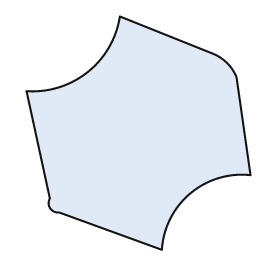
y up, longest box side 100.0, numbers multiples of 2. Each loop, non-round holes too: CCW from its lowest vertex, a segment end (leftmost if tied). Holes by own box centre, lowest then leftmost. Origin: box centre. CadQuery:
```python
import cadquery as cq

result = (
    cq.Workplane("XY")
    .moveTo(10.0, -50.0)
    .threePointArc((22.0, -26.0), (48.0, -18.0))
    .lineTo(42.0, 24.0)
    .threePointArc((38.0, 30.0), (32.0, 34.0))
    .lineTo(-8.0, 50.0)
    .threePointArc((-22.0, 26.0), (-48.0, 18.0))
    .lineTo(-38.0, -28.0)
    .threePointArc((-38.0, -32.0), (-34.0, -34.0))
    .close()
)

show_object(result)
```